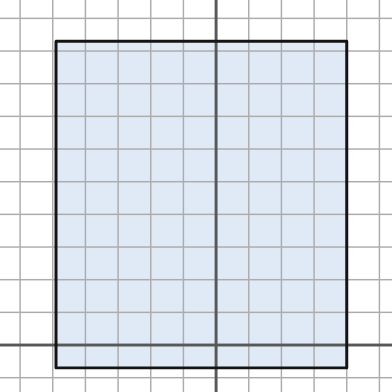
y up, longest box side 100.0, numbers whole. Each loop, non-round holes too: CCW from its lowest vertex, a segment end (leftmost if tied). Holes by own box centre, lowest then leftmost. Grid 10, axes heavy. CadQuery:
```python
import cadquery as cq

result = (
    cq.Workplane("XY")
    .moveTo(-49.0, -7.0)
    .lineTo(40.0, -7.0)
    .lineTo(40.0, 93.0)
    .lineTo(-49.0, 93.0)
    .close()
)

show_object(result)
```